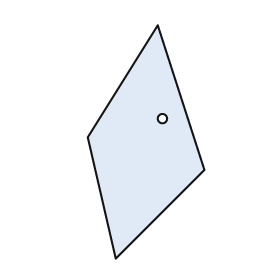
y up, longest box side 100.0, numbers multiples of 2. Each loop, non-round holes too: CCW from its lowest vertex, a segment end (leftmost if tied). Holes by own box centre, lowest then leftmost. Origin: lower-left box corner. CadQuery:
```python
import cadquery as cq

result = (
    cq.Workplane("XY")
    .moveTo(12.0, 0.0)
    .lineTo(50.0, 38.0)
    .lineTo(30.0, 100.0)
    .lineTo(0.0, 52.0)
    .close()
    .moveTo(32.0, 60.0)
    .circle(2.0)
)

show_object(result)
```